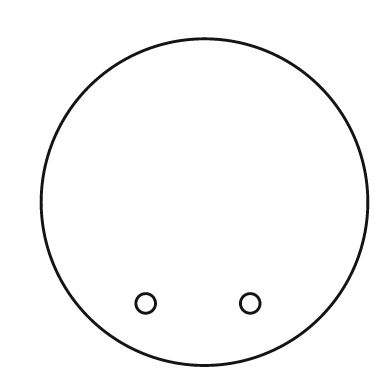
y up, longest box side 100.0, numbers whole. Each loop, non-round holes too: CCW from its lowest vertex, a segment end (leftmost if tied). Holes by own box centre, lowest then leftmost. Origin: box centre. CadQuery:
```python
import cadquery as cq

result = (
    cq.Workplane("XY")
    .moveTo(0.0, 0.0)
    .circle(50.0)
    .moveTo(-18.0, -31.0)
    .circle(3.0)
    .moveTo(14.0, -31.0)
    .circle(3.0)
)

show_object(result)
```